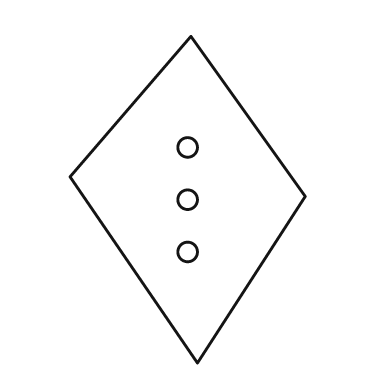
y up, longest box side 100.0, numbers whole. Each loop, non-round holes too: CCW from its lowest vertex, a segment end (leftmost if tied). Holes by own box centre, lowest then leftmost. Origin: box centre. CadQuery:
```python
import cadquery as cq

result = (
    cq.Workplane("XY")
    .moveTo(3.0, -50.0)
    .lineTo(36.0, 1.0)
    .lineTo(1.0, 50.0)
    .lineTo(-36.0, 7.0)
    .close()
    .moveTo(0.0, -16.0)
    .circle(3.0)
    .moveTo(0.0, 0.0)
    .circle(3.0)
    .moveTo(0.0, 16.0)
    .circle(3.0)
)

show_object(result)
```